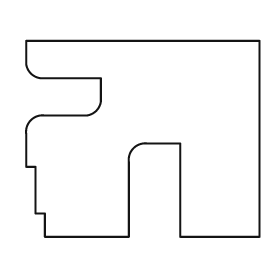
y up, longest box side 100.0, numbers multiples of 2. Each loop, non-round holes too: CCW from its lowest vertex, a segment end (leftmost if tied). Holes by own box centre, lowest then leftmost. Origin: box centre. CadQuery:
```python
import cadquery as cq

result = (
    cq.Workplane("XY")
    .moveTo(-42.0, -42.0)
    .lineTo(-6.0, -42.0)
    .lineTo(-6.0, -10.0)
    .threePointArc((-4.0, -4.0), (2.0, -2.0))
    .lineTo(16.0, -2.0)
    .lineTo(16.0, -42.0)
    .lineTo(50.0, -42.0)
    .lineTo(50.0, 42.0)
    .lineTo(-50.0, 42.0)
    .lineTo(-50.0, 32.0)
    .threePointArc((-48.0, 28.0), (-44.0, 26.0))
    .lineTo(-18.0, 26.0)
    .lineTo(-18.0, 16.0)
    .threePointArc((-20.0, 12.0), (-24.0, 10.0))
    .lineTo(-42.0, 10.0)
    .threePointArc((-48.0, 8.0), (-50.0, 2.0))
    .lineTo(-50.0, -12.0)
    .lineTo(-46.0, -12.0)
    .lineTo(-46.0, -32.0)
    .lineTo(-42.0, -32.0)
    .close()
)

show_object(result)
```